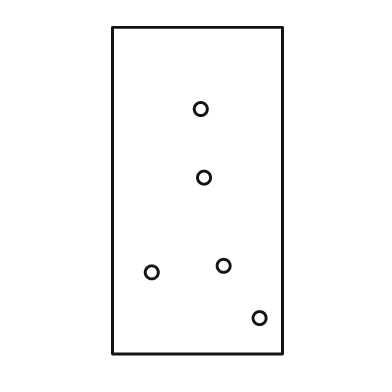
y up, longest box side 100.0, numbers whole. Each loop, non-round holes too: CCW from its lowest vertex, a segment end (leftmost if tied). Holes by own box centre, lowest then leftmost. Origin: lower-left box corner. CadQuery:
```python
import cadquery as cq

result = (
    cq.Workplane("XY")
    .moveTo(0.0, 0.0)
    .lineTo(52.0, 0.0)
    .lineTo(52.0, 100.0)
    .lineTo(0.0, 100.0)
    .close()
    .moveTo(45.0, 11.0)
    .circle(2.0)
    .moveTo(12.0, 25.0)
    .circle(2.0)
    .moveTo(34.0, 27.0)
    .circle(2.0)
    .moveTo(28.0, 54.0)
    .circle(2.0)
    .moveTo(27.0, 75.0)
    .circle(2.0)
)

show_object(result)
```